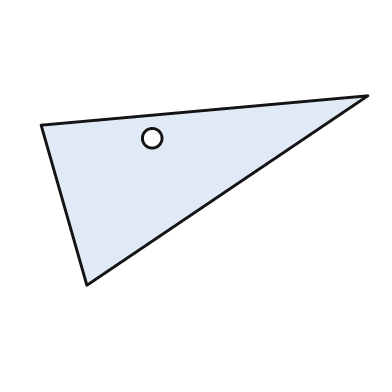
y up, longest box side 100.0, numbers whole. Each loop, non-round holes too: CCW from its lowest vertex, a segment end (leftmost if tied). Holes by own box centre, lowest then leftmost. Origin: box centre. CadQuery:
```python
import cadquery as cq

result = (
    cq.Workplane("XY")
    .moveTo(-36.0, -29.0)
    .lineTo(50.0, 29.0)
    .lineTo(-50.0, 20.0)
    .close()
    .moveTo(-16.0, 16.0)
    .circle(3.0)
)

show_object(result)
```